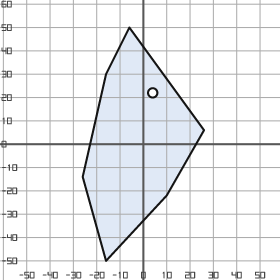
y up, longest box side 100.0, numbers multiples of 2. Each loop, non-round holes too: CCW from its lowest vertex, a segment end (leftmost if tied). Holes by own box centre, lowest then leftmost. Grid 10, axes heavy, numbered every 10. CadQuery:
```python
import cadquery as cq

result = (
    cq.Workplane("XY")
    .moveTo(-16.0, -50.0)
    .lineTo(10.0, -22.0)
    .lineTo(26.0, 6.0)
    .lineTo(-6.0, 50.0)
    .lineTo(-16.0, 30.0)
    .lineTo(-26.0, -14.0)
    .close()
    .moveTo(4.0, 22.0)
    .circle(2.0)
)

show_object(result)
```